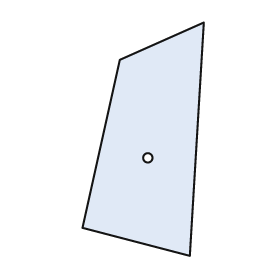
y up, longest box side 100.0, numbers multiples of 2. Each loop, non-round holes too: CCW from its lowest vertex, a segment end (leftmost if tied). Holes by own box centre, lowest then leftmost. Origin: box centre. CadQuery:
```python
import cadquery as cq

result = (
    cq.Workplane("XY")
    .moveTo(20.0, -50.0)
    .lineTo(26.0, 50.0)
    .lineTo(-10.0, 34.0)
    .lineTo(-26.0, -38.0)
    .close()
    .moveTo(2.0, -8.0)
    .circle(2.0)
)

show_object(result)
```